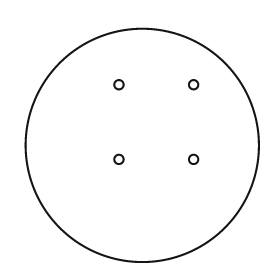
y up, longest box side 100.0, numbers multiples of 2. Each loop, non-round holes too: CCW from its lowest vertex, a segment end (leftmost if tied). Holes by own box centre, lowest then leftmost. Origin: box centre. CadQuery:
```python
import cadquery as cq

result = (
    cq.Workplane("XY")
    .moveTo(0.0, 0.0)
    .circle(50.0)
    .moveTo(-10.0, -6.0)
    .circle(2.0)
    .moveTo(22.0, -6.0)
    .circle(2.0)
    .moveTo(-10.0, 26.0)
    .circle(2.0)
    .moveTo(22.0, 26.0)
    .circle(2.0)
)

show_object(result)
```